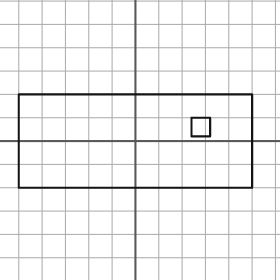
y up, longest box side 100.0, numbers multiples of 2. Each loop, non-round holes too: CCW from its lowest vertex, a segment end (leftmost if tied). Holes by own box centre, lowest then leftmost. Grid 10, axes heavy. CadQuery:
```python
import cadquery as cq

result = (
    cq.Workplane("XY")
    .moveTo(-50.0, -20.0)
    .lineTo(50.0, -20.0)
    .lineTo(50.0, 20.0)
    .lineTo(-50.0, 20.0)
    .close()
    .moveTo(24.0, 2.0)
    .lineTo(32.0, 2.0)
    .lineTo(32.0, 10.0)
    .lineTo(24.0, 10.0)
    .close()
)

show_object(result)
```